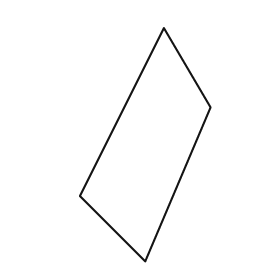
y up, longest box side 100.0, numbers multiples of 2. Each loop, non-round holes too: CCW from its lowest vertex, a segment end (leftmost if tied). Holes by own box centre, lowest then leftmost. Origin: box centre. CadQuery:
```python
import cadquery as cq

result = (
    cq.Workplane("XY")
    .moveTo(0.0, -50.0)
    .lineTo(28.0, 16.0)
    .lineTo(8.0, 50.0)
    .lineTo(-28.0, -22.0)
    .close()
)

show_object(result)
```